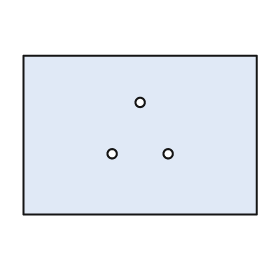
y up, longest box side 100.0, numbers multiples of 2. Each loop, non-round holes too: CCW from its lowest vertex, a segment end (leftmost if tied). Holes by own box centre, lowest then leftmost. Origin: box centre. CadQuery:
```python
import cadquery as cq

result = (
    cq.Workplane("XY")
    .moveTo(-50.0, -34.0)
    .lineTo(50.0, -34.0)
    .lineTo(50.0, 34.0)
    .lineTo(-50.0, 34.0)
    .close()
    .moveTo(-12.0, -8.0)
    .circle(2.0)
    .moveTo(12.0, -8.0)
    .circle(2.0)
    .moveTo(0.0, 14.0)
    .circle(2.0)
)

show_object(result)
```